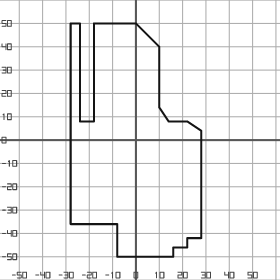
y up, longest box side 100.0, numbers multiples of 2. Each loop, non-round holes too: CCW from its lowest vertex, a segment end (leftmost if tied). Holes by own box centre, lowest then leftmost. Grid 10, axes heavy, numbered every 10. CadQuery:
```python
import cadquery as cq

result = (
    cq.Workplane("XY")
    .moveTo(-8.0, -50.0)
    .lineTo(16.0, -50.0)
    .lineTo(16.0, -46.0)
    .lineTo(22.0, -46.0)
    .lineTo(22.0, -42.0)
    .lineTo(28.0, -42.0)
    .lineTo(28.0, 4.0)
    .lineTo(22.0, 8.0)
    .lineTo(14.0, 8.0)
    .lineTo(10.0, 14.0)
    .lineTo(10.0, 40.0)
    .lineTo(0.0, 50.0)
    .lineTo(-18.0, 50.0)
    .lineTo(-18.0, 8.0)
    .lineTo(-24.0, 8.0)
    .lineTo(-24.0, 50.0)
    .lineTo(-28.0, 50.0)
    .lineTo(-28.0, -36.0)
    .lineTo(-8.0, -36.0)
    .close()
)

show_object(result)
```